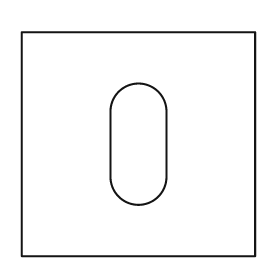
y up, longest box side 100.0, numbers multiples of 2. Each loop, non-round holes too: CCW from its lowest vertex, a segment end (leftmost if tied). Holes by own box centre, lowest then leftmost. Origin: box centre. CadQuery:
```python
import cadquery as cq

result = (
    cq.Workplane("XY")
    .moveTo(-50.0, -48.0)
    .lineTo(50.0, -48.0)
    .lineTo(50.0, 48.0)
    .lineTo(-50.0, 48.0)
    .close()
    .moveTo(-12.0, -14.0)
    .threePointArc((0.0, -26.0), (12.0, -14.0))
    .lineTo(12.0, 14.0)
    .threePointArc((0.0, 26.0), (-12.0, 14.0))
    .close()
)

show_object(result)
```